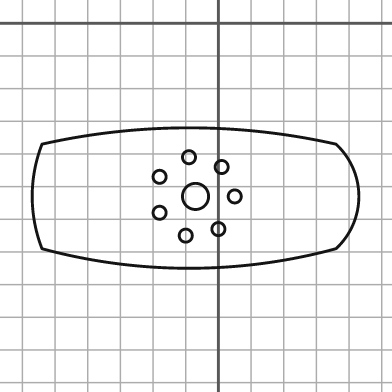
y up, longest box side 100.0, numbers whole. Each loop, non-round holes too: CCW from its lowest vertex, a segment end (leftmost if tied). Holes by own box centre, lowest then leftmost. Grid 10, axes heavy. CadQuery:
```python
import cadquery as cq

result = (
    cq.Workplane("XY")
    .moveTo(-54.0, -69.0)
    .threePointArc((-9.0, -75.0), (36.0, -69.0))
    .threePointArc((43.0, -53.0), (36.0, -37.0))
    .threePointArc((-9.0, -32.0), (-54.0, -37.0))
    .threePointArc((-57.0, -53.0), (-54.0, -69.0))
    .close()
    .moveTo(-10.0, -65.0)
    .circle(2.0)
    .moveTo(0.0, -63.0)
    .circle(2.0)
    .moveTo(-18.0, -58.0)
    .circle(2.0)
    .moveTo(-7.0, -53.0)
    .circle(4.0)
    .moveTo(5.0, -53.0)
    .circle(2.0)
    .moveTo(-18.0, -47.0)
    .circle(2.0)
    .moveTo(1.0, -44.0)
    .circle(2.0)
    .moveTo(-9.0, -41.0)
    .circle(2.0)
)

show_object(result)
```